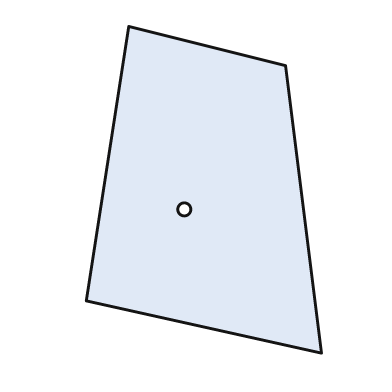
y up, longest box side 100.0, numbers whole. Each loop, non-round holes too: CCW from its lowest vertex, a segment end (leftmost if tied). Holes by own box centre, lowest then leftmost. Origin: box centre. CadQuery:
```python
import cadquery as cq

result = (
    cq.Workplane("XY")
    .moveTo(36.0, -50.0)
    .lineTo(25.0, 38.0)
    .lineTo(-23.0, 50.0)
    .lineTo(-36.0, -34.0)
    .close()
    .moveTo(-6.0, -6.0)
    .circle(2.0)
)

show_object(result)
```